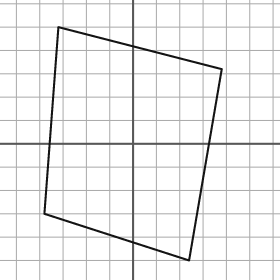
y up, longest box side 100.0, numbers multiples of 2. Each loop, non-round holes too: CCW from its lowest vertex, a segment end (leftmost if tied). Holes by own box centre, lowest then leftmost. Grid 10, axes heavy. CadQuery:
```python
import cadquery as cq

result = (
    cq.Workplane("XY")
    .moveTo(24.0, -50.0)
    .lineTo(38.0, 32.0)
    .lineTo(-32.0, 50.0)
    .lineTo(-38.0, -30.0)
    .close()
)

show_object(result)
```